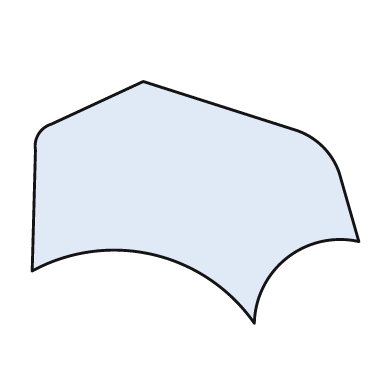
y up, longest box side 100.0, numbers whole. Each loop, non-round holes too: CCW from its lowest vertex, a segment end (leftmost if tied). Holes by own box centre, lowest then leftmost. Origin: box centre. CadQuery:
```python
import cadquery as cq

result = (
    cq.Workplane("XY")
    .moveTo(18.0, -37.0)
    .threePointArc((28.0, -17.0), (50.0, -12.0))
    .lineTo(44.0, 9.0)
    .threePointArc((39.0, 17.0), (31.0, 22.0))
    .lineTo(-16.0, 37.0)
    .lineTo(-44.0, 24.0)
    .threePointArc((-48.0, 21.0), (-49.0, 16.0))
    .lineTo(-50.0, -21.0)
    .threePointArc((-13.0, -16.0), (18.0, -37.0))
    .close()
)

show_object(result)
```